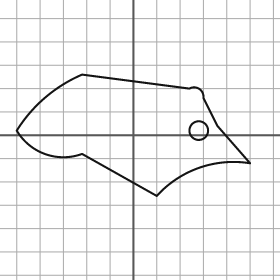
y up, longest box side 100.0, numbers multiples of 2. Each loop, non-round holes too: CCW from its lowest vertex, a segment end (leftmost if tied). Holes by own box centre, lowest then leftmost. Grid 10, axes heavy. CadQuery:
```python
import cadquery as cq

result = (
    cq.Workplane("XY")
    .moveTo(10.0, -26.0)
    .threePointArc((28.0, -14.0), (50.0, -12.0))
    .lineTo(36.0, 4.0)
    .lineTo(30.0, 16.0)
    .threePointArc((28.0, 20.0), (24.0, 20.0))
    .lineTo(-22.0, 26.0)
    .threePointArc((-38.0, 16.0), (-50.0, 2.0))
    .threePointArc((-38.0, -8.0), (-22.0, -8.0))
    .close()
    .moveTo(28.0, 2.0)
    .circle(4.0)
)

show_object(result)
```